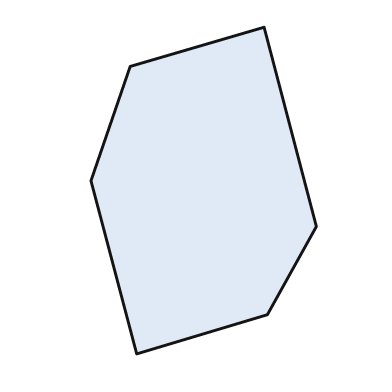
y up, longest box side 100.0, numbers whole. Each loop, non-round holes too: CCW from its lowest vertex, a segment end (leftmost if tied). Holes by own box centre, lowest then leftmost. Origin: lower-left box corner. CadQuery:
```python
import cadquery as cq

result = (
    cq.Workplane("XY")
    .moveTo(14.0, 0.0)
    .lineTo(54.0, 12.0)
    .lineTo(69.0, 39.0)
    .lineTo(53.0, 100.0)
    .lineTo(12.0, 88.0)
    .lineTo(0.0, 53.0)
    .close()
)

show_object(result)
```